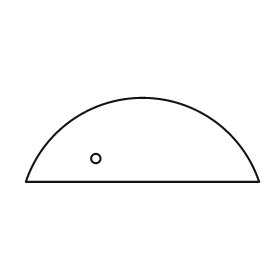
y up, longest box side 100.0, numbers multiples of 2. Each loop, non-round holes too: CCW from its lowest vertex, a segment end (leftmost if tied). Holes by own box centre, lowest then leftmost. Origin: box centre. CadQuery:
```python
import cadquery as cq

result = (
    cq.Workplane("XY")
    .moveTo(-50.0, -18.0)
    .lineTo(50.0, -18.0)
    .threePointArc((0.0, 18.0), (-50.0, -18.0))
    .close()
    .moveTo(-20.0, -8.0)
    .circle(2.0)
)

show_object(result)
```